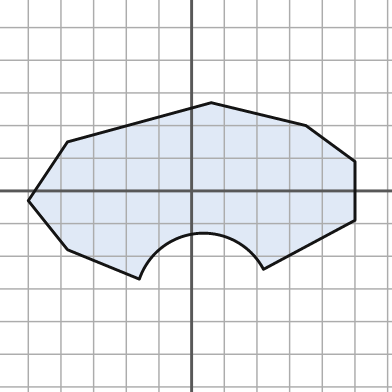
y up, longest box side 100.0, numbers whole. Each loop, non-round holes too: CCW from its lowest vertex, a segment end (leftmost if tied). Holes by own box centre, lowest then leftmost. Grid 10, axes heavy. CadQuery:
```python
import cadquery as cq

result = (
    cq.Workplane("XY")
    .moveTo(-16.0, -27.0)
    .threePointArc((2.0, -13.0), (22.0, -24.0))
    .lineTo(50.0, -9.0)
    .lineTo(50.0, 9.0)
    .lineTo(35.0, 20.0)
    .lineTo(6.0, 27.0)
    .lineTo(-38.0, 15.0)
    .lineTo(-50.0, -3.0)
    .lineTo(-38.0, -18.0)
    .close()
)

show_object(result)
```